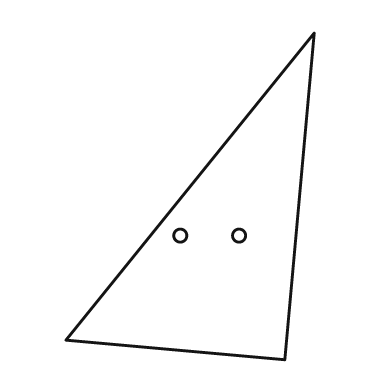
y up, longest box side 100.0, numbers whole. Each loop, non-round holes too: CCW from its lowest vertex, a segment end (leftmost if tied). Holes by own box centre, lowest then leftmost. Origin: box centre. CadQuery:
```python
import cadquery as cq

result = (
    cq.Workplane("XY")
    .moveTo(29.0, -50.0)
    .lineTo(38.0, 50.0)
    .lineTo(-38.0, -44.0)
    .close()
    .moveTo(-3.0, -12.0)
    .circle(2.0)
    .moveTo(15.0, -12.0)
    .circle(2.0)
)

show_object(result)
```